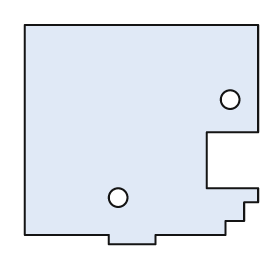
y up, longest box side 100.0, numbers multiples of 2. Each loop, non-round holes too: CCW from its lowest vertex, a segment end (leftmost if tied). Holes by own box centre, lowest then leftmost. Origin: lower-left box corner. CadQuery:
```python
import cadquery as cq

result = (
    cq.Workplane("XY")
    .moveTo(36.0, 0.0)
    .lineTo(56.0, 0.0)
    .lineTo(56.0, 4.0)
    .lineTo(86.0, 4.0)
    .lineTo(86.0, 10.0)
    .lineTo(94.0, 10.0)
    .lineTo(94.0, 18.0)
    .lineTo(100.0, 18.0)
    .lineTo(100.0, 24.0)
    .lineTo(78.0, 24.0)
    .lineTo(78.0, 48.0)
    .lineTo(100.0, 48.0)
    .lineTo(100.0, 94.0)
    .lineTo(0.0, 94.0)
    .lineTo(0.0, 4.0)
    .lineTo(36.0, 4.0)
    .close()
    .moveTo(40.0, 20.0)
    .circle(4.0)
    .moveTo(88.0, 62.0)
    .circle(4.0)
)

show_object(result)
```